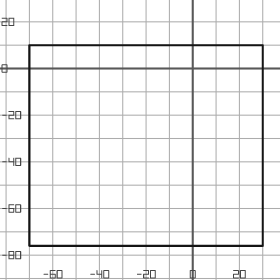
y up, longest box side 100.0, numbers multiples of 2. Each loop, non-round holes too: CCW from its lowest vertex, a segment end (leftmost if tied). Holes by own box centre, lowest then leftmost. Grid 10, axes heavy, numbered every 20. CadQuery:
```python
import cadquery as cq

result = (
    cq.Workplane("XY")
    .moveTo(-70.0, -76.0)
    .lineTo(30.0, -76.0)
    .lineTo(30.0, 10.0)
    .lineTo(-70.0, 10.0)
    .close()
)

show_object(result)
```